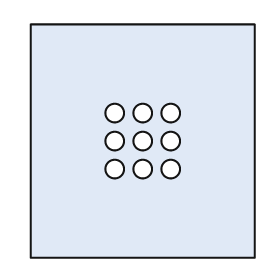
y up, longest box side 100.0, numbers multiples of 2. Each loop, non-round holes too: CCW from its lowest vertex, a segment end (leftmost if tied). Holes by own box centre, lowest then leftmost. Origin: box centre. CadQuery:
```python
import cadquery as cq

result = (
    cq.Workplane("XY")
    .moveTo(-48.0, -50.0)
    .lineTo(48.0, -50.0)
    .lineTo(48.0, 50.0)
    .lineTo(-48.0, 50.0)
    .close()
    .moveTo(-12.0, -12.0)
    .circle(4.0)
    .moveTo(0.0, -12.0)
    .circle(4.0)
    .moveTo(12.0, -12.0)
    .circle(4.0)
    .moveTo(-12.0, 0.0)
    .circle(4.0)
    .moveTo(0.0, 0.0)
    .circle(4.0)
    .moveTo(12.0, 0.0)
    .circle(4.0)
    .moveTo(-12.0, 12.0)
    .circle(4.0)
    .moveTo(0.0, 12.0)
    .circle(4.0)
    .moveTo(12.0, 12.0)
    .circle(4.0)
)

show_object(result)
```